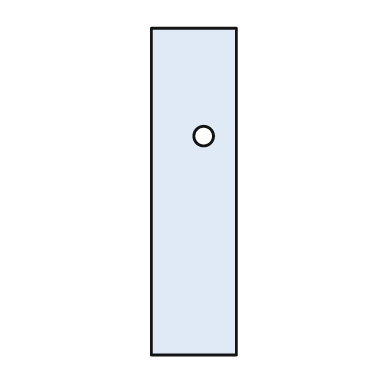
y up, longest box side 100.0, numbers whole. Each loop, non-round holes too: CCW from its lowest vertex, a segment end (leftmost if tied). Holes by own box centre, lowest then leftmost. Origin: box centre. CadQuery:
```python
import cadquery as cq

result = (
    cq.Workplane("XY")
    .moveTo(-13.0, -50.0)
    .lineTo(13.0, -50.0)
    .lineTo(13.0, 50.0)
    .lineTo(-13.0, 50.0)
    .close()
    .moveTo(3.0, 17.0)
    .circle(3.0)
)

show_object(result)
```